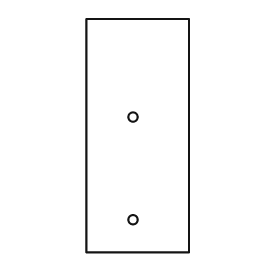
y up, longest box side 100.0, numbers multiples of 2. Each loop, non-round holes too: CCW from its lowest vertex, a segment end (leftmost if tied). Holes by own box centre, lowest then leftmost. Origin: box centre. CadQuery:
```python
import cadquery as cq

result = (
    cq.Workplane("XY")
    .moveTo(-22.0, -50.0)
    .lineTo(22.0, -50.0)
    .lineTo(22.0, 50.0)
    .lineTo(-22.0, 50.0)
    .close()
    .moveTo(-2.0, -36.0)
    .circle(2.0)
    .moveTo(-2.0, 8.0)
    .circle(2.0)
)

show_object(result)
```